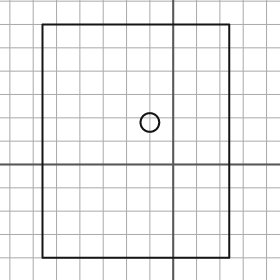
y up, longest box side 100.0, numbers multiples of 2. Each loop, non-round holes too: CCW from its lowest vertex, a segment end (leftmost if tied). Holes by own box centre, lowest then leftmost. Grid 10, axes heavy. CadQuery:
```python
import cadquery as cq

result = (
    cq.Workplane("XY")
    .moveTo(-56.0, -40.0)
    .lineTo(24.0, -40.0)
    .lineTo(24.0, 60.0)
    .lineTo(-56.0, 60.0)
    .close()
    .moveTo(-10.0, 18.0)
    .circle(4.0)
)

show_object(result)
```